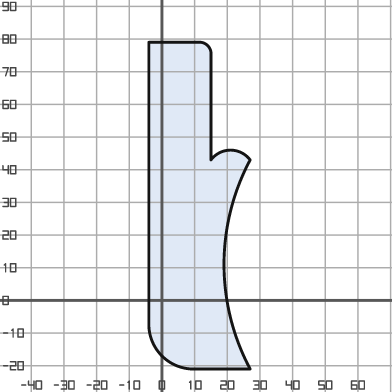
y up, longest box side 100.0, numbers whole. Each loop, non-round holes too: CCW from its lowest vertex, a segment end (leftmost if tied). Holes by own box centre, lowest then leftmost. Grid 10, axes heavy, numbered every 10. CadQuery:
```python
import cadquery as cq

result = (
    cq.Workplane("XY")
    .moveTo(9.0, -21.0)
    .lineTo(27.0, -21.0)
    .threePointArc((19.0, 11.0), (27.0, 43.0))
    .threePointArc((21.0, 46.0), (15.0, 43.0))
    .lineTo(15.0, 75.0)
    .threePointArc((14.0, 78.0), (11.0, 79.0))
    .lineTo(-4.0, 79.0)
    .lineTo(-4.0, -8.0)
    .threePointArc((0.0, -17.0), (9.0, -21.0))
    .close()
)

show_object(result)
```